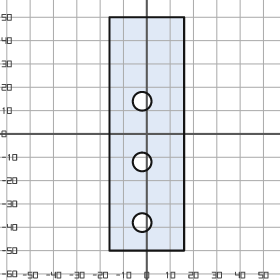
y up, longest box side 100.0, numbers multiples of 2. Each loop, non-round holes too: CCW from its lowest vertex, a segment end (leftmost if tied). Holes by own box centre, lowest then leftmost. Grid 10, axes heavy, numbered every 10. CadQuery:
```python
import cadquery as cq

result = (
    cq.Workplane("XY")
    .moveTo(-16.0, -50.0)
    .lineTo(16.0, -50.0)
    .lineTo(16.0, 50.0)
    .lineTo(-16.0, 50.0)
    .close()
    .moveTo(-2.0, -38.0)
    .circle(4.0)
    .moveTo(-2.0, -12.0)
    .circle(4.0)
    .moveTo(-2.0, 14.0)
    .circle(4.0)
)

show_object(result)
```